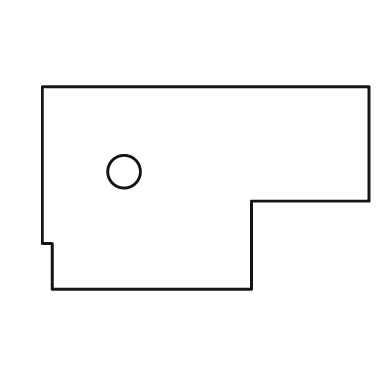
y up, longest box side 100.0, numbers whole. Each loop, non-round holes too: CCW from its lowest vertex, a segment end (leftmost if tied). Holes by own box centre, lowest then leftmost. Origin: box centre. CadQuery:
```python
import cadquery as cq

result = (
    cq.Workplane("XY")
    .moveTo(-47.0, -31.0)
    .lineTo(14.0, -31.0)
    .lineTo(14.0, -4.0)
    .lineTo(50.0, -4.0)
    .lineTo(50.0, 31.0)
    .lineTo(-50.0, 31.0)
    .lineTo(-50.0, -17.0)
    .lineTo(-47.0, -17.0)
    .close()
    .moveTo(-25.0, 5.0)
    .circle(5.0)
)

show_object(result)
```